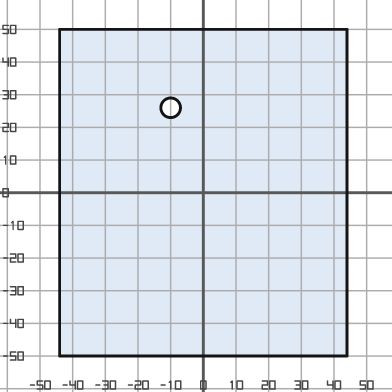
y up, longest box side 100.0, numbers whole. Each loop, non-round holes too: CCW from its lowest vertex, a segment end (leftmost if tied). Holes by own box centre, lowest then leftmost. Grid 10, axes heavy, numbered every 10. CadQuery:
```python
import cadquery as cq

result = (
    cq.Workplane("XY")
    .moveTo(-44.0, -50.0)
    .lineTo(44.0, -50.0)
    .lineTo(44.0, 50.0)
    .lineTo(-44.0, 50.0)
    .close()
    .moveTo(-10.0, 26.0)
    .circle(3.0)
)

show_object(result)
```